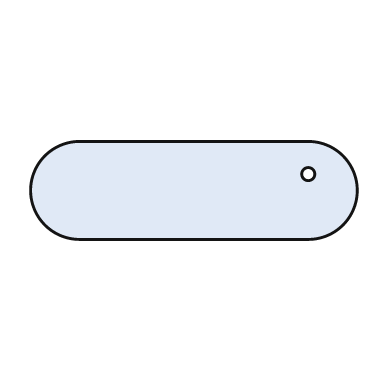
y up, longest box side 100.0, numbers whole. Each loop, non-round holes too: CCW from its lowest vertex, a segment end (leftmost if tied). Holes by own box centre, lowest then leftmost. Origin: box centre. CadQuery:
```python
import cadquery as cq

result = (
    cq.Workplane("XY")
    .moveTo(-35.0, -15.0)
    .lineTo(35.0, -15.0)
    .threePointArc((50.0, 0.0), (35.0, 15.0))
    .lineTo(-35.0, 15.0)
    .threePointArc((-50.0, 0.0), (-35.0, -15.0))
    .close()
    .moveTo(35.0, 5.0)
    .circle(2.0)
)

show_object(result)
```